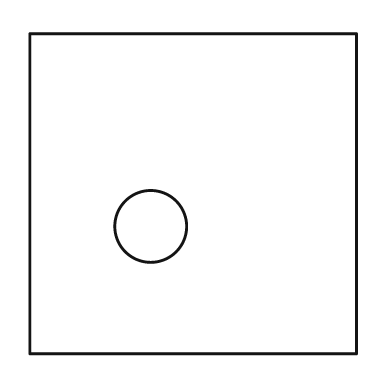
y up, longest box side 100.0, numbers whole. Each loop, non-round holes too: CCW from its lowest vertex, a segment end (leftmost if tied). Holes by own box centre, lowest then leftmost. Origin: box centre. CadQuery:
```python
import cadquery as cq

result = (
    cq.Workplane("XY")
    .moveTo(-50.0, -49.0)
    .lineTo(50.0, -49.0)
    .lineTo(50.0, 49.0)
    .lineTo(-50.0, 49.0)
    .close()
    .moveTo(-13.0, -10.0)
    .circle(11.0)
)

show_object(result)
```